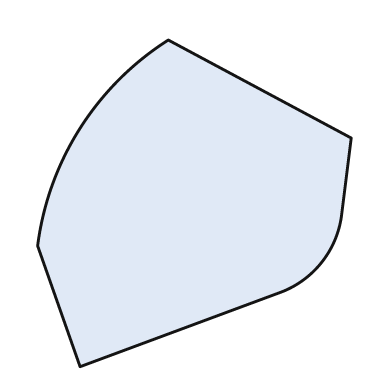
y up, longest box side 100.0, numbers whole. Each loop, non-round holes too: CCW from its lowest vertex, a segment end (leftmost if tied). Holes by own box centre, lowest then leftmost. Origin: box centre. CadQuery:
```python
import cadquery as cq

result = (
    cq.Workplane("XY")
    .moveTo(-35.0, -50.0)
    .lineTo(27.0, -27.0)
    .threePointArc((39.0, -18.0), (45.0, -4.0))
    .lineTo(48.0, 20.0)
    .lineTo(-8.0, 50.0)
    .threePointArc((-35.0, 23.0), (-48.0, -13.0))
    .close()
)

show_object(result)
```